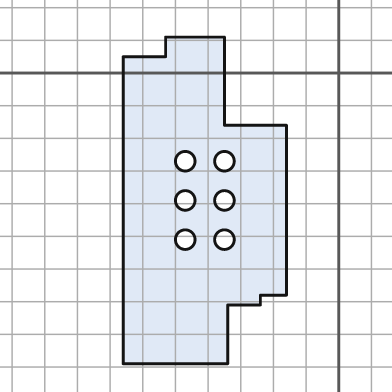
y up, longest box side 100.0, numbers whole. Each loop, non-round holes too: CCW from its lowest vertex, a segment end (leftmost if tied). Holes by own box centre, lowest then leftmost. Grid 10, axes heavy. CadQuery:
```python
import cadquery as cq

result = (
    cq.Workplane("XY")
    .moveTo(-66.0, -89.0)
    .lineTo(-34.0, -89.0)
    .lineTo(-34.0, -71.0)
    .lineTo(-24.0, -71.0)
    .lineTo(-24.0, -68.0)
    .lineTo(-16.0, -68.0)
    .lineTo(-16.0, -16.0)
    .lineTo(-35.0, -16.0)
    .lineTo(-35.0, 11.0)
    .lineTo(-53.0, 11.0)
    .lineTo(-53.0, 5.0)
    .lineTo(-66.0, 5.0)
    .close()
    .moveTo(-47.0, -51.0)
    .circle(3.0)
    .moveTo(-35.0, -51.0)
    .circle(3.0)
    .moveTo(-47.0, -39.0)
    .circle(3.0)
    .moveTo(-35.0, -39.0)
    .circle(3.0)
    .moveTo(-47.0, -27.0)
    .circle(3.0)
    .moveTo(-35.0, -27.0)
    .circle(3.0)
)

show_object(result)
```